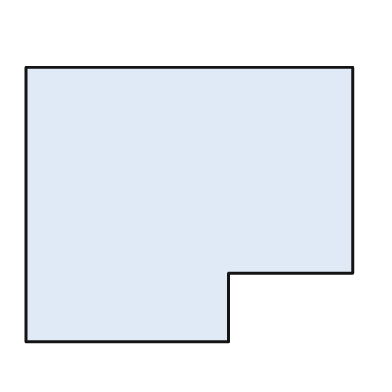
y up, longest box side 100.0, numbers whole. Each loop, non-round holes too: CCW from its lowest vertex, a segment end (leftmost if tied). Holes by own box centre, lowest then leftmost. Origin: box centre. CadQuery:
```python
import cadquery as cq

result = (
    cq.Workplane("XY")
    .moveTo(-50.0, -42.0)
    .lineTo(12.0, -42.0)
    .lineTo(12.0, -21.0)
    .lineTo(50.0, -21.0)
    .lineTo(50.0, 42.0)
    .lineTo(-50.0, 42.0)
    .close()
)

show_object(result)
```